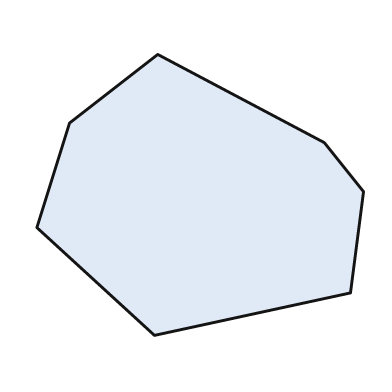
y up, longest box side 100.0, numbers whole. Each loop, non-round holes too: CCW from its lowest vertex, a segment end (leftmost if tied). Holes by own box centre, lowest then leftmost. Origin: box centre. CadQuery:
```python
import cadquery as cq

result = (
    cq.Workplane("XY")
    .moveTo(-14.0, -43.0)
    .lineTo(46.0, -30.0)
    .lineTo(50.0, 1.0)
    .lineTo(38.0, 16.0)
    .lineTo(-13.0, 43.0)
    .lineTo(-40.0, 22.0)
    .lineTo(-50.0, -10.0)
    .close()
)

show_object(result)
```